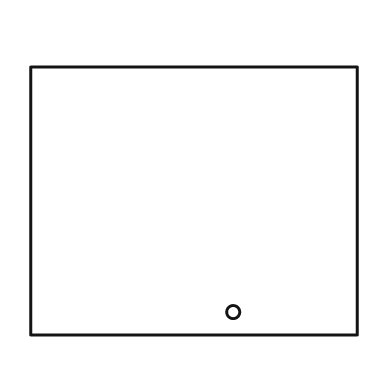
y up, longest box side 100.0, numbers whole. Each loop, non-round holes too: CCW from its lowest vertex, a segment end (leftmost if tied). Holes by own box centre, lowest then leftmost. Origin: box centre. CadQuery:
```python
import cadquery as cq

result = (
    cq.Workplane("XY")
    .moveTo(-50.0, -41.0)
    .lineTo(50.0, -41.0)
    .lineTo(50.0, 41.0)
    .lineTo(-50.0, 41.0)
    .close()
    .moveTo(12.0, -34.0)
    .circle(2.0)
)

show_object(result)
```